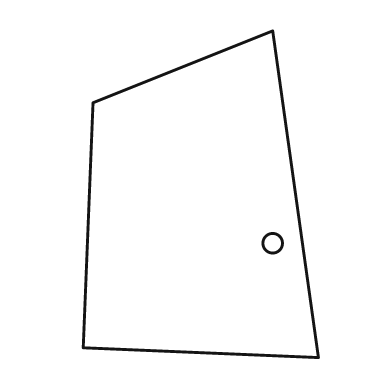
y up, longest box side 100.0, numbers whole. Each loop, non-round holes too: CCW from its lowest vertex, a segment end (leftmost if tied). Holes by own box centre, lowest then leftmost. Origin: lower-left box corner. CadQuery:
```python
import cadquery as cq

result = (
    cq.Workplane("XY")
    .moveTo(72.0, 0.0)
    .lineTo(58.0, 100.0)
    .lineTo(3.0, 78.0)
    .lineTo(0.0, 3.0)
    .close()
    .moveTo(58.0, 35.0)
    .circle(3.0)
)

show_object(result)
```